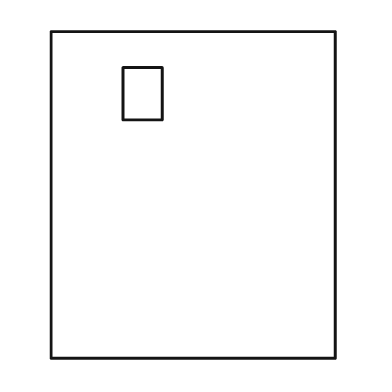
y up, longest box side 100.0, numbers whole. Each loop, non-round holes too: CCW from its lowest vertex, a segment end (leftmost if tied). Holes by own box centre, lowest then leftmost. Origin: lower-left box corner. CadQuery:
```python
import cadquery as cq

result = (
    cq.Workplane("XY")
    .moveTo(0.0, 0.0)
    .lineTo(87.0, 0.0)
    .lineTo(87.0, 100.0)
    .lineTo(0.0, 100.0)
    .close()
    .moveTo(22.0, 73.0)
    .lineTo(34.0, 73.0)
    .lineTo(34.0, 89.0)
    .lineTo(22.0, 89.0)
    .close()
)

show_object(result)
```